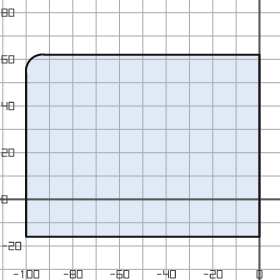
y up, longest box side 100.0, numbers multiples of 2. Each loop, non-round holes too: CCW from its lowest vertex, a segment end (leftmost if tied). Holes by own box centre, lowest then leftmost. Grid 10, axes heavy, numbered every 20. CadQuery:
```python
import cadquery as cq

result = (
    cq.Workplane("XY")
    .moveTo(-100.0, -16.0)
    .lineTo(0.0, -16.0)
    .lineTo(0.0, 62.0)
    .lineTo(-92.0, 62.0)
    .threePointArc((-98.0, 60.0), (-100.0, 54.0))
    .close()
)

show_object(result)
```